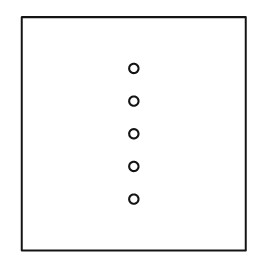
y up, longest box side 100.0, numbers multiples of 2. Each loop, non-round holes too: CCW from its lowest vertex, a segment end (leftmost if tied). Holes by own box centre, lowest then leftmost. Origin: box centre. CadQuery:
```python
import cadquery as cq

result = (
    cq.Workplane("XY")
    .moveTo(-48.0, -50.0)
    .lineTo(48.0, -50.0)
    .lineTo(48.0, 50.0)
    .lineTo(-48.0, 50.0)
    .close()
    .moveTo(0.0, -28.0)
    .circle(2.0)
    .moveTo(0.0, -14.0)
    .circle(2.0)
    .moveTo(0.0, 0.0)
    .circle(2.0)
    .moveTo(0.0, 14.0)
    .circle(2.0)
    .moveTo(0.0, 28.0)
    .circle(2.0)
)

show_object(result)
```